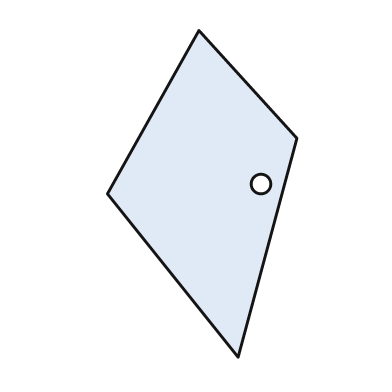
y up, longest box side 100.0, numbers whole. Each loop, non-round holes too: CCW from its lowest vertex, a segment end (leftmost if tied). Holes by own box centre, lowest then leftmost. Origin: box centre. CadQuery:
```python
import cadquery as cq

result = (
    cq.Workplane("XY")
    .moveTo(11.0, -50.0)
    .lineTo(29.0, 17.0)
    .lineTo(-1.0, 50.0)
    .lineTo(-29.0, 0.0)
    .close()
    .moveTo(18.0, 3.0)
    .circle(3.0)
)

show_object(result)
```